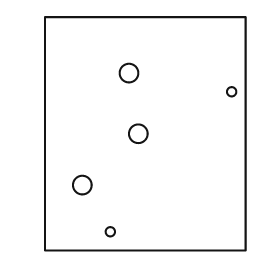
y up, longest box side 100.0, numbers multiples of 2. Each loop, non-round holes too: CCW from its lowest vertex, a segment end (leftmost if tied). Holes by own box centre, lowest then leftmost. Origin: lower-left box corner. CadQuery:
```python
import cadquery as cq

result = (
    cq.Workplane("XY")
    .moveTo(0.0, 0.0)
    .lineTo(86.0, 0.0)
    .lineTo(86.0, 100.0)
    .lineTo(0.0, 100.0)
    .close()
    .moveTo(28.0, 8.0)
    .circle(2.0)
    .moveTo(16.0, 28.0)
    .circle(4.0)
    .moveTo(40.0, 50.0)
    .circle(4.0)
    .moveTo(80.0, 68.0)
    .circle(2.0)
    .moveTo(36.0, 76.0)
    .circle(4.0)
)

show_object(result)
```